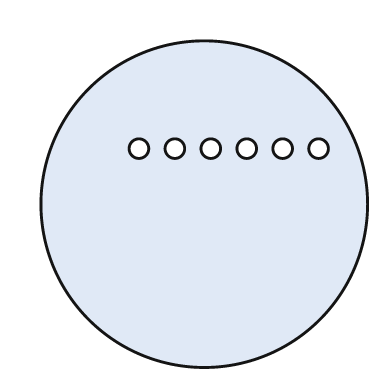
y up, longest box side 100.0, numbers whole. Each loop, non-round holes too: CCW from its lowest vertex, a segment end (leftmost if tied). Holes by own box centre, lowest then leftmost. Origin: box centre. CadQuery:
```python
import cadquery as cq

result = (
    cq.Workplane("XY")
    .moveTo(0.0, 0.0)
    .circle(50.0)
    .moveTo(-20.0, 17.0)
    .circle(3.0)
    .moveTo(-9.0, 17.0)
    .circle(3.0)
    .moveTo(2.0, 17.0)
    .circle(3.0)
    .moveTo(13.0, 17.0)
    .circle(3.0)
    .moveTo(24.0, 17.0)
    .circle(3.0)
    .moveTo(35.0, 17.0)
    .circle(3.0)
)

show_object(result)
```